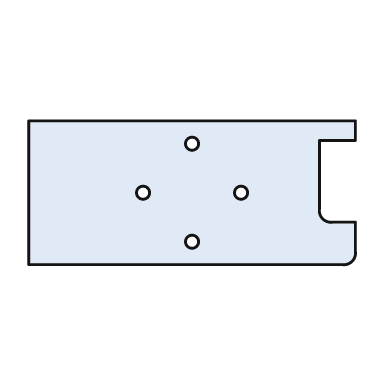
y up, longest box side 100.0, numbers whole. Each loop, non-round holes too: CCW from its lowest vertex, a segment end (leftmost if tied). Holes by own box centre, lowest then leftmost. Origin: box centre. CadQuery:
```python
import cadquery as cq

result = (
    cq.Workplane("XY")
    .moveTo(-50.0, -22.0)
    .lineTo(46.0, -22.0)
    .threePointArc((49.0, -21.0), (50.0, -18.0))
    .lineTo(50.0, -9.0)
    .lineTo(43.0, -9.0)
    .threePointArc((40.0, -8.0), (39.0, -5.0))
    .lineTo(39.0, 16.0)
    .lineTo(50.0, 16.0)
    .lineTo(50.0, 22.0)
    .lineTo(-50.0, 22.0)
    .close()
    .moveTo(0.0, -15.0)
    .circle(2.0)
    .moveTo(-15.0, 0.0)
    .circle(2.0)
    .moveTo(15.0, 0.0)
    .circle(2.0)
    .moveTo(0.0, 15.0)
    .circle(2.0)
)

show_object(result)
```